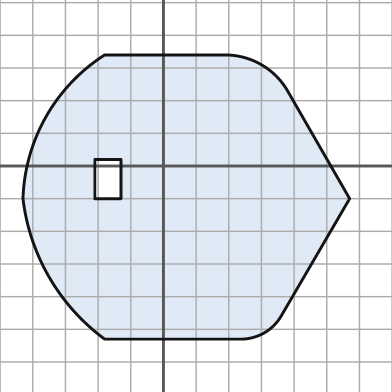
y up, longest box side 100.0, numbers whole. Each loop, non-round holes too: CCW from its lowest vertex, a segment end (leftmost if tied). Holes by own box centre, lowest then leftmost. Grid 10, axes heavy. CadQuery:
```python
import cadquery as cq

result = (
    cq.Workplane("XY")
    .moveTo(-18.0, -53.0)
    .lineTo(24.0, -53.0)
    .threePointArc((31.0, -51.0), (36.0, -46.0))
    .lineTo(57.0, -10.0)
    .lineTo(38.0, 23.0)
    .threePointArc((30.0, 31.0), (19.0, 34.0))
    .lineTo(-18.0, 34.0)
    .threePointArc((-36.0, 15.0), (-43.0, -10.0))
    .threePointArc((-35.0, -34.0), (-18.0, -53.0))
    .close()
    .moveTo(-21.0, -10.0)
    .lineTo(-13.0, -10.0)
    .lineTo(-13.0, 2.0)
    .lineTo(-21.0, 2.0)
    .close()
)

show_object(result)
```